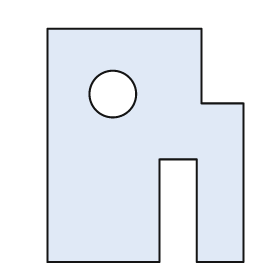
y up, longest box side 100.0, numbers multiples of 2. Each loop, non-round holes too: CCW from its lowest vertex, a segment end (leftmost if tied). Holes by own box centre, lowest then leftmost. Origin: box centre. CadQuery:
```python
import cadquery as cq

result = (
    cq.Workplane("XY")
    .moveTo(-42.0, -50.0)
    .lineTo(6.0, -50.0)
    .lineTo(6.0, -6.0)
    .lineTo(22.0, -6.0)
    .lineTo(22.0, -50.0)
    .lineTo(42.0, -50.0)
    .lineTo(42.0, 18.0)
    .lineTo(24.0, 18.0)
    .lineTo(24.0, 50.0)
    .lineTo(-42.0, 50.0)
    .close()
    .moveTo(-14.0, 22.0)
    .circle(10.0)
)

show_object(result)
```